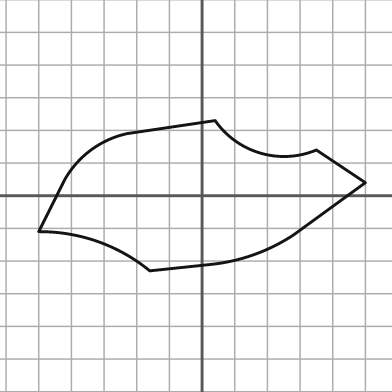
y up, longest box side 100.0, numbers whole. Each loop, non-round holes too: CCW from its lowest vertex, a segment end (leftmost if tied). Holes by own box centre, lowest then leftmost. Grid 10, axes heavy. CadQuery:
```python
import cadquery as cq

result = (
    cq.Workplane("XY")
    .moveTo(-16.0, -23.0)
    .lineTo(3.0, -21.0)
    .threePointArc((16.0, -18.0), (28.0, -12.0))
    .lineTo(50.0, 4.0)
    .lineTo(35.0, 14.0)
    .threePointArc((18.0, 13.0), (4.0, 23.0))
    .lineTo(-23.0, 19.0)
    .threePointArc((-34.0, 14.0), (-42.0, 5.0))
    .lineTo(-50.0, -11.0)
    .threePointArc((-32.0, -14.0), (-16.0, -23.0))
    .close()
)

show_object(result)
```